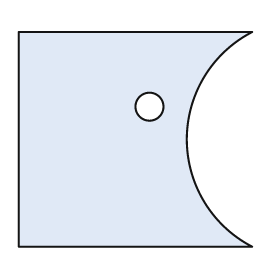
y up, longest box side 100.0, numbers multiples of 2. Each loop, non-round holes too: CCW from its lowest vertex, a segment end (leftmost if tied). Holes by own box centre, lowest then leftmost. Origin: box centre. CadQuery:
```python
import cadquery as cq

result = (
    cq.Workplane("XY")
    .moveTo(-50.0, -46.0)
    .lineTo(50.0, -46.0)
    .threePointArc((22.0, 0.0), (50.0, 46.0))
    .lineTo(-50.0, 46.0)
    .close()
    .moveTo(6.0, 14.0)
    .circle(6.0)
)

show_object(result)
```